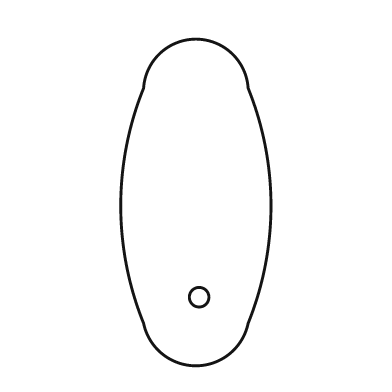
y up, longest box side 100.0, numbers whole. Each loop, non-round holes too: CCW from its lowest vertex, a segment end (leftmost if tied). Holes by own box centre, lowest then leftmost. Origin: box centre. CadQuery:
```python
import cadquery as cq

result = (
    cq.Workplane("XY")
    .moveTo(-16.0, -37.0)
    .threePointArc((0.0, -50.0), (16.0, -37.0))
    .threePointArc((23.0, -1.0), (16.0, 35.0))
    .threePointArc((0.0, 50.0), (-16.0, 35.0))
    .threePointArc((-23.0, -1.0), (-16.0, -37.0))
    .close()
    .moveTo(1.0, -29.0)
    .circle(3.0)
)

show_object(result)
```